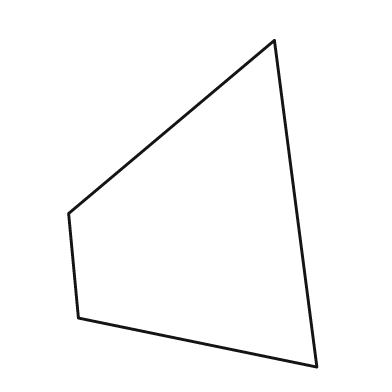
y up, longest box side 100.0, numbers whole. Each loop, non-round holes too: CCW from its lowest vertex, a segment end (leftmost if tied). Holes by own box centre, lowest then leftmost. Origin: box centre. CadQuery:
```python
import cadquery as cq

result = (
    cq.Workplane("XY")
    .moveTo(38.0, -50.0)
    .lineTo(25.0, 50.0)
    .lineTo(-38.0, -3.0)
    .lineTo(-35.0, -35.0)
    .close()
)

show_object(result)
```